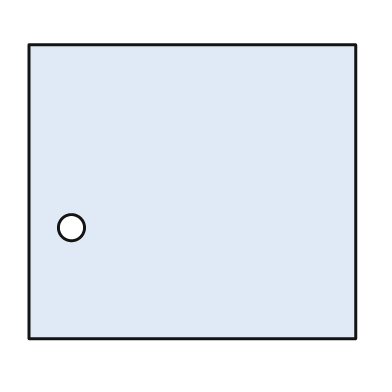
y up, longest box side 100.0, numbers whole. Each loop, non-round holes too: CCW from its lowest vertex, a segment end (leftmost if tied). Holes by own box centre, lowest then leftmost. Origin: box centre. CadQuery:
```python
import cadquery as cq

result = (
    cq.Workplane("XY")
    .moveTo(-50.0, -45.0)
    .lineTo(50.0, -45.0)
    .lineTo(50.0, 45.0)
    .lineTo(-50.0, 45.0)
    .close()
    .moveTo(-37.0, -11.0)
    .circle(4.0)
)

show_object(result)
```